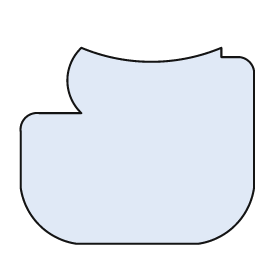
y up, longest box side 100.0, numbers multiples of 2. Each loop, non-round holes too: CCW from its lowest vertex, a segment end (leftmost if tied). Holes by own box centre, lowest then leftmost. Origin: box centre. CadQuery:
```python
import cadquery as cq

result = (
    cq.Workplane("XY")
    .moveTo(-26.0, -42.0)
    .lineTo(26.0, -42.0)
    .threePointArc((42.0, -34.0), (50.0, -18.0))
    .lineTo(50.0, 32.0)
    .threePointArc((48.0, 36.0), (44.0, 38.0))
    .lineTo(36.0, 38.0)
    .lineTo(36.0, 42.0)
    .threePointArc((6.0, 36.0), (-24.0, 42.0))
    .threePointArc((-30.0, 28.0), (-24.0, 14.0))
    .lineTo(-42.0, 14.0)
    .threePointArc((-48.0, 12.0), (-50.0, 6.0))
    .lineTo(-50.0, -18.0)
    .threePointArc((-42.0, -34.0), (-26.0, -42.0))
    .close()
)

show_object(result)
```